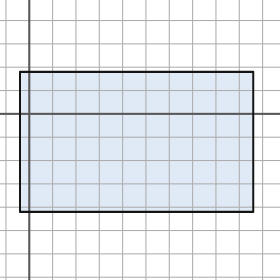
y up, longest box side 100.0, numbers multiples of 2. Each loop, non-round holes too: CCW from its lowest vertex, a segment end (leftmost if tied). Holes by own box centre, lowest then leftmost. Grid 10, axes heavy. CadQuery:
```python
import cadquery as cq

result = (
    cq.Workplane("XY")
    .moveTo(-4.0, -42.0)
    .lineTo(96.0, -42.0)
    .lineTo(96.0, 18.0)
    .lineTo(-4.0, 18.0)
    .close()
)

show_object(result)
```